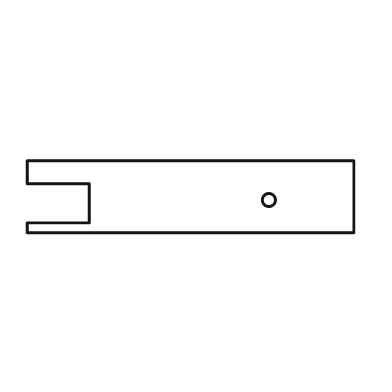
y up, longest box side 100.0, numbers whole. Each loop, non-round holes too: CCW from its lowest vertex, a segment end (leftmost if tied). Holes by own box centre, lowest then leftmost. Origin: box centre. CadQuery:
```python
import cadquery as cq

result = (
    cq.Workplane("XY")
    .moveTo(-50.0, -11.0)
    .lineTo(50.0, -11.0)
    .lineTo(50.0, 11.0)
    .lineTo(-50.0, 11.0)
    .lineTo(-50.0, 4.0)
    .lineTo(-31.0, 4.0)
    .lineTo(-31.0, -8.0)
    .lineTo(-50.0, -8.0)
    .close()
    .moveTo(24.0, -1.0)
    .circle(2.0)
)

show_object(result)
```